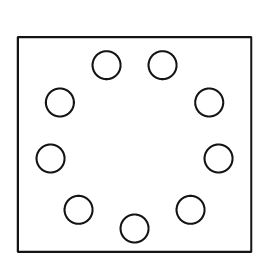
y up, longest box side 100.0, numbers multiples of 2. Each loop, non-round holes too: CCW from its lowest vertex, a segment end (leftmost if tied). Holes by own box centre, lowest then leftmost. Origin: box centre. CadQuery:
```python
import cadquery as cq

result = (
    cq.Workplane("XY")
    .moveTo(-50.0, -46.0)
    .lineTo(50.0, -46.0)
    .lineTo(50.0, 46.0)
    .lineTo(-50.0, 46.0)
    .close()
    .moveTo(0.0, -36.0)
    .circle(6.0)
    .moveTo(-24.0, -28.0)
    .circle(6.0)
    .moveTo(24.0, -28.0)
    .circle(6.0)
    .moveTo(-36.0, -6.0)
    .circle(6.0)
    .moveTo(36.0, -6.0)
    .circle(6.0)
    .moveTo(-32.0, 18.0)
    .circle(6.0)
    .moveTo(32.0, 18.0)
    .circle(6.0)
    .moveTo(-12.0, 34.0)
    .circle(6.0)
    .moveTo(12.0, 34.0)
    .circle(6.0)
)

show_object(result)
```